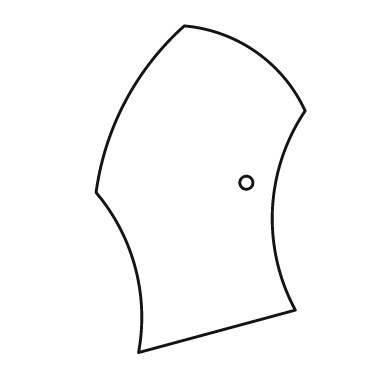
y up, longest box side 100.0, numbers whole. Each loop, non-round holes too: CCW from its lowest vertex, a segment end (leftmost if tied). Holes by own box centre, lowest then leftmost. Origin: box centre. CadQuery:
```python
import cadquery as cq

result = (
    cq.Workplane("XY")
    .moveTo(-19.0, -50.0)
    .lineTo(29.0, -37.0)
    .threePointArc((22.0, -6.0), (32.0, 24.0))
    .threePointArc((17.0, 42.0), (-5.0, 50.0))
    .threePointArc((-23.0, 27.0), (-32.0, -1.0))
    .threePointArc((-20.0, -24.0), (-19.0, -50.0))
    .close()
    .moveTo(14.0, 2.0)
    .circle(2.0)
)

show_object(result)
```